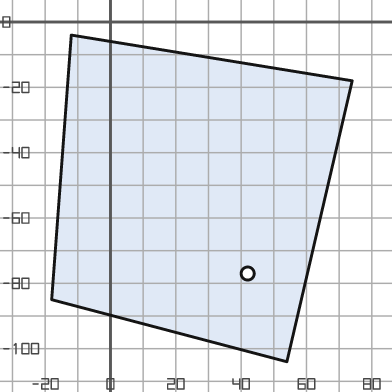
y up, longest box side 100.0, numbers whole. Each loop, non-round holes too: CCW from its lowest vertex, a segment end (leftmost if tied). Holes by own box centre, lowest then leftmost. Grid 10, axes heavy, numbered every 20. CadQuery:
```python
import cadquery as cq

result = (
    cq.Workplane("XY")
    .moveTo(54.0, -104.0)
    .lineTo(74.0, -18.0)
    .lineTo(-12.0, -4.0)
    .lineTo(-18.0, -85.0)
    .close()
    .moveTo(42.0, -77.0)
    .circle(2.0)
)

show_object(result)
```